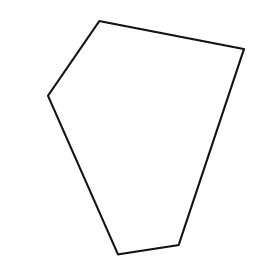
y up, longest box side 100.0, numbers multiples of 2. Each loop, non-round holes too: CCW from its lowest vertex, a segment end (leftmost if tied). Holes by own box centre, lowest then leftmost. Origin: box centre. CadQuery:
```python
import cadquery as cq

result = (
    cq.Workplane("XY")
    .moveTo(-12.0, -50.0)
    .lineTo(14.0, -46.0)
    .lineTo(42.0, 38.0)
    .lineTo(-20.0, 50.0)
    .lineTo(-42.0, 18.0)
    .close()
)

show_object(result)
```